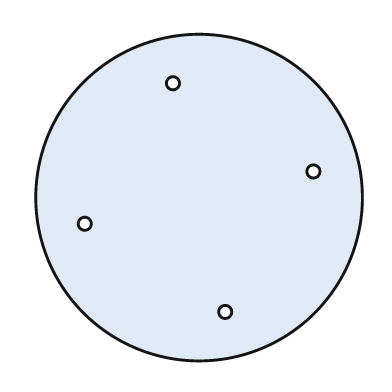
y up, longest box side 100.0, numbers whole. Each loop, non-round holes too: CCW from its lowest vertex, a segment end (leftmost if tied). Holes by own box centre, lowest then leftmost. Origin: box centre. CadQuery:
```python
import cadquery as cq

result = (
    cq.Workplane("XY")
    .moveTo(0.0, 0.0)
    .circle(50.0)
    .moveTo(8.0, -35.0)
    .circle(2.0)
    .moveTo(-35.0, -8.0)
    .circle(2.0)
    .moveTo(35.0, 8.0)
    .circle(2.0)
    .moveTo(-8.0, 35.0)
    .circle(2.0)
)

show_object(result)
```